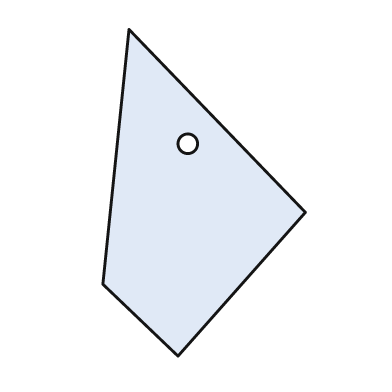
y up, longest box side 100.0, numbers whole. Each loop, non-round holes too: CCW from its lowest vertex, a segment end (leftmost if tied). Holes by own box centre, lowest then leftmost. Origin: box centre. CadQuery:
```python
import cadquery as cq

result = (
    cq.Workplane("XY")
    .moveTo(-8.0, -50.0)
    .lineTo(31.0, -6.0)
    .lineTo(-23.0, 50.0)
    .lineTo(-31.0, -28.0)
    .close()
    .moveTo(-5.0, 15.0)
    .circle(3.0)
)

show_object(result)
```